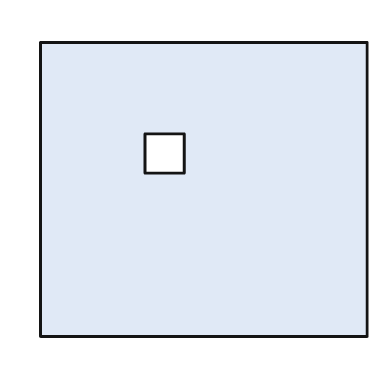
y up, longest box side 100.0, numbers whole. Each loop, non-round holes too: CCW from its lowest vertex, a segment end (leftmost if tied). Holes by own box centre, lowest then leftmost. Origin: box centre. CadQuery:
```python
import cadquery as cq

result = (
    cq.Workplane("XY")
    .moveTo(-50.0, -45.0)
    .lineTo(50.0, -45.0)
    .lineTo(50.0, 45.0)
    .lineTo(-50.0, 45.0)
    .close()
    .moveTo(-18.0, 5.0)
    .lineTo(-6.0, 5.0)
    .lineTo(-6.0, 17.0)
    .lineTo(-18.0, 17.0)
    .close()
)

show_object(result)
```